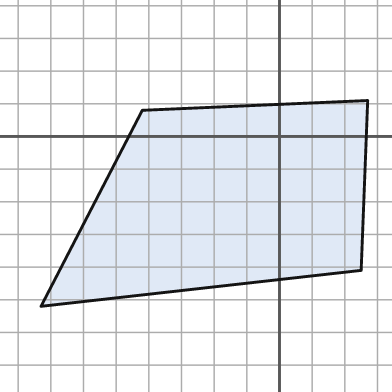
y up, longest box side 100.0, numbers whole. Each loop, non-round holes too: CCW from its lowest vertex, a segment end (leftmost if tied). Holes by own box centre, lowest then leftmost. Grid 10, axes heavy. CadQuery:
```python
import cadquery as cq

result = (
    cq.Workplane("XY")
    .moveTo(-73.0, -52.0)
    .lineTo(25.0, -41.0)
    .lineTo(27.0, 11.0)
    .lineTo(-42.0, 8.0)
    .close()
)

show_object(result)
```